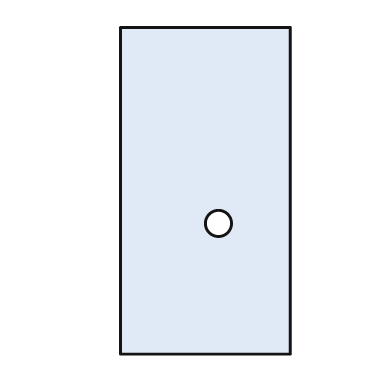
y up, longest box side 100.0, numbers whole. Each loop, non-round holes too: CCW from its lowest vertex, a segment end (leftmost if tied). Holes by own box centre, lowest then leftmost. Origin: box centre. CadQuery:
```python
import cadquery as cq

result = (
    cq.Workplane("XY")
    .moveTo(-26.0, -50.0)
    .lineTo(26.0, -50.0)
    .lineTo(26.0, 50.0)
    .lineTo(-26.0, 50.0)
    .close()
    .moveTo(4.0, -10.0)
    .circle(4.0)
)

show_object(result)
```